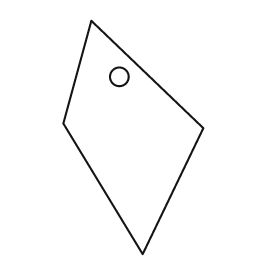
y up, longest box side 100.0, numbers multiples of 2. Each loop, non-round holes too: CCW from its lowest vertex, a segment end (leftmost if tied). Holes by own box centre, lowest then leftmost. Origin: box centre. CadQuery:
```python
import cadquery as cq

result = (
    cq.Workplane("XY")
    .moveTo(4.0, -50.0)
    .lineTo(30.0, 4.0)
    .lineTo(-18.0, 50.0)
    .lineTo(-30.0, 6.0)
    .close()
    .moveTo(-6.0, 26.0)
    .circle(4.0)
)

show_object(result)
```